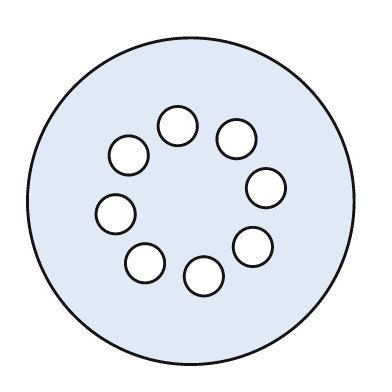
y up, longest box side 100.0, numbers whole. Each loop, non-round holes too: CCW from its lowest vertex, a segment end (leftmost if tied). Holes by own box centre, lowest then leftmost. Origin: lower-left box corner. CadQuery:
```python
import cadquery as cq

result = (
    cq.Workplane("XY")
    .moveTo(50.0, 50.0)
    .circle(50.0)
    .moveTo(54.0, 27.0)
    .circle(6.0)
    .moveTo(36.0, 31.0)
    .circle(6.0)
    .moveTo(69.0, 36.0)
    .circle(6.0)
    .moveTo(27.0, 46.0)
    .circle(6.0)
    .moveTo(73.0, 54.0)
    .circle(6.0)
    .moveTo(31.0, 64.0)
    .circle(6.0)
    .moveTo(64.0, 69.0)
    .circle(6.0)
    .moveTo(46.0, 73.0)
    .circle(6.0)
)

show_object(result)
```